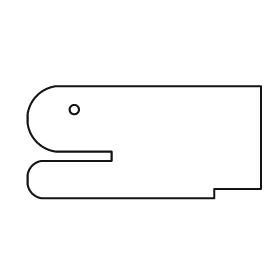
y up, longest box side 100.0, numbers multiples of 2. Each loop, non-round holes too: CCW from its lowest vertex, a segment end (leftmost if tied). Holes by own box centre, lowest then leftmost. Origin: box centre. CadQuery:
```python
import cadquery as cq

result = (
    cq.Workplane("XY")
    .moveTo(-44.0, -24.0)
    .lineTo(30.0, -24.0)
    .lineTo(30.0, -20.0)
    .lineTo(50.0, -20.0)
    .lineTo(50.0, 24.0)
    .lineTo(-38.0, 24.0)
    .threePointArc((-46.0, 20.0), (-50.0, 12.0))
    .lineTo(-50.0, 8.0)
    .threePointArc((-46.0, 0.0), (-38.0, -4.0))
    .lineTo(-14.0, -4.0)
    .lineTo(-14.0, -8.0)
    .lineTo(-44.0, -8.0)
    .threePointArc((-48.0, -10.0), (-50.0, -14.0))
    .lineTo(-50.0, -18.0)
    .threePointArc((-48.0, -22.0), (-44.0, -24.0))
    .close()
    .moveTo(-30.0, 14.0)
    .circle(2.0)
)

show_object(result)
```